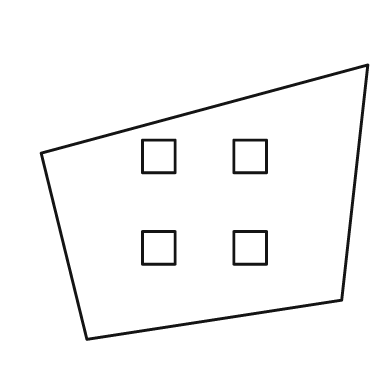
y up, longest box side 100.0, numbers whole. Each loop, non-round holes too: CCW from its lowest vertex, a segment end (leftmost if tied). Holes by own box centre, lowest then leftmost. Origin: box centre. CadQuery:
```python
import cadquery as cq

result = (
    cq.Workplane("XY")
    .moveTo(-36.0, -42.0)
    .lineTo(42.0, -30.0)
    .lineTo(50.0, 42.0)
    .lineTo(-50.0, 15.0)
    .close()
    .moveTo(-19.0, -19.0)
    .lineTo(-9.0, -19.0)
    .lineTo(-9.0, -9.0)
    .lineTo(-19.0, -9.0)
    .close()
    .moveTo(9.0, -19.0)
    .lineTo(19.0, -19.0)
    .lineTo(19.0, -9.0)
    .lineTo(9.0, -9.0)
    .close()
    .moveTo(-19.0, 9.0)
    .lineTo(-9.0, 9.0)
    .lineTo(-9.0, 19.0)
    .lineTo(-19.0, 19.0)
    .close()
    .moveTo(9.0, 9.0)
    .lineTo(19.0, 9.0)
    .lineTo(19.0, 19.0)
    .lineTo(9.0, 19.0)
    .close()
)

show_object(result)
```